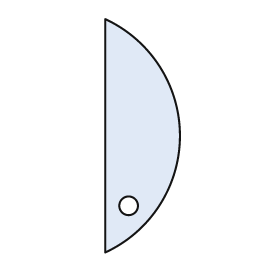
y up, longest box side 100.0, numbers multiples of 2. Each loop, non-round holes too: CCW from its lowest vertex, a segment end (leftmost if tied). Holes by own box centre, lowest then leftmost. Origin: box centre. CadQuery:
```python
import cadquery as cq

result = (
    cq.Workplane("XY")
    .moveTo(-16.0, -50.0)
    .threePointArc((16.0, 0.0), (-16.0, 50.0))
    .close()
    .moveTo(-6.0, -30.0)
    .circle(4.0)
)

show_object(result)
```